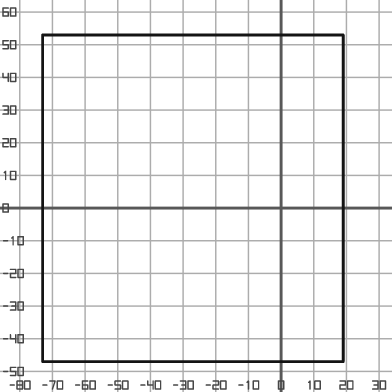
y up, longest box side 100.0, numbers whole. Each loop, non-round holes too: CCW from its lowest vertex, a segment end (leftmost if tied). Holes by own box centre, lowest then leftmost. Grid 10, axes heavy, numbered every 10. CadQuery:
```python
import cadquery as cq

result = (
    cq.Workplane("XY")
    .moveTo(-73.0, -47.0)
    .lineTo(19.0, -47.0)
    .lineTo(19.0, 53.0)
    .lineTo(-73.0, 53.0)
    .close()
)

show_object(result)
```